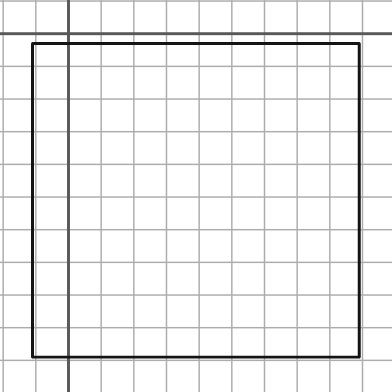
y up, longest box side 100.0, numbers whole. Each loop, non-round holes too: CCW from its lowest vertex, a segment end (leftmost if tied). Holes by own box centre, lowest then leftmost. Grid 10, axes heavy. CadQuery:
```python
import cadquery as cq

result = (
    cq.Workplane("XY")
    .moveTo(-11.0, -99.0)
    .lineTo(89.0, -99.0)
    .lineTo(89.0, -3.0)
    .lineTo(-11.0, -3.0)
    .close()
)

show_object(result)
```